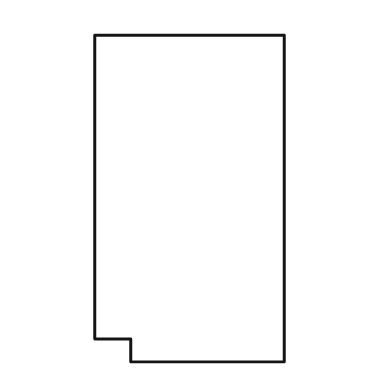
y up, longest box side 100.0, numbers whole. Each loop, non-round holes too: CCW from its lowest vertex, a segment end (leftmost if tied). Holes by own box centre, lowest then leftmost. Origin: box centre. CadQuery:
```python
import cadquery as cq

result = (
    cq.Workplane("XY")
    .moveTo(-18.0, -50.0)
    .lineTo(29.0, -50.0)
    .lineTo(29.0, 50.0)
    .lineTo(-29.0, 50.0)
    .lineTo(-29.0, -43.0)
    .lineTo(-18.0, -43.0)
    .close()
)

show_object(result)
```